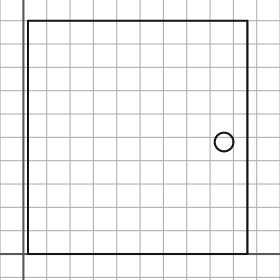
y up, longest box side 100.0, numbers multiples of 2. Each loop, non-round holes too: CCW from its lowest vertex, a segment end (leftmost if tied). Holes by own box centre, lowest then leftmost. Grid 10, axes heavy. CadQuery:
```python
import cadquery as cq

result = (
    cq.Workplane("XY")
    .moveTo(2.0, 0.0)
    .lineTo(96.0, 0.0)
    .lineTo(96.0, 100.0)
    .lineTo(2.0, 100.0)
    .close()
    .moveTo(86.0, 48.0)
    .circle(4.0)
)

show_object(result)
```